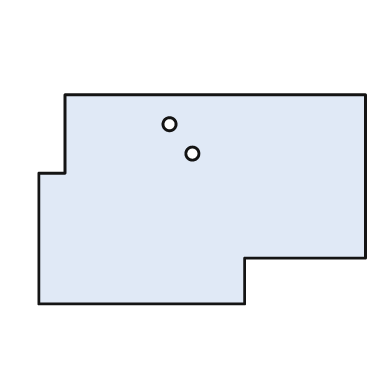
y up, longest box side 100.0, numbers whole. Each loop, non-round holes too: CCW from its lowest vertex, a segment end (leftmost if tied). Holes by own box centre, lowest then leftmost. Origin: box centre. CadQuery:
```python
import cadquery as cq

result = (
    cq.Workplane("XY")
    .moveTo(-50.0, -32.0)
    .lineTo(13.0, -32.0)
    .lineTo(13.0, -18.0)
    .lineTo(50.0, -18.0)
    .lineTo(50.0, 32.0)
    .lineTo(-42.0, 32.0)
    .lineTo(-42.0, 8.0)
    .lineTo(-50.0, 8.0)
    .close()
    .moveTo(-3.0, 14.0)
    .circle(2.0)
    .moveTo(-10.0, 23.0)
    .circle(2.0)
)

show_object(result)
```